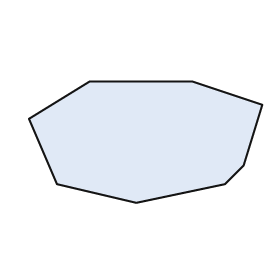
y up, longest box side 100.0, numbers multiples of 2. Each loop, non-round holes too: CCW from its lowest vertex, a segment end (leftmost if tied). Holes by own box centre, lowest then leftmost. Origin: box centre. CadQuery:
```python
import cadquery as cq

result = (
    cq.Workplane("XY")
    .moveTo(-4.0, -26.0)
    .lineTo(34.0, -18.0)
    .lineTo(42.0, -10.0)
    .lineTo(50.0, 16.0)
    .lineTo(20.0, 26.0)
    .lineTo(-24.0, 26.0)
    .lineTo(-50.0, 10.0)
    .lineTo(-38.0, -18.0)
    .close()
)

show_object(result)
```